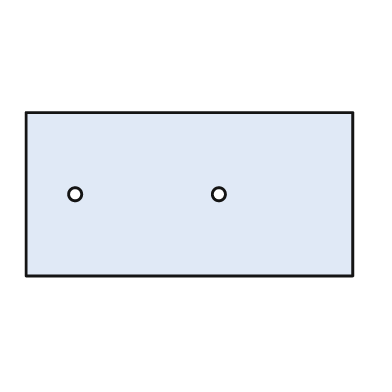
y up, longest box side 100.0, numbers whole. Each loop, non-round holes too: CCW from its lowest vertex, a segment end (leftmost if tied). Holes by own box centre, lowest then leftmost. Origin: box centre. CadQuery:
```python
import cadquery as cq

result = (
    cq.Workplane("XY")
    .moveTo(-50.0, -25.0)
    .lineTo(50.0, -25.0)
    .lineTo(50.0, 25.0)
    .lineTo(-50.0, 25.0)
    .close()
    .moveTo(-35.0, 0.0)
    .circle(2.0)
    .moveTo(9.0, 0.0)
    .circle(2.0)
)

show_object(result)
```